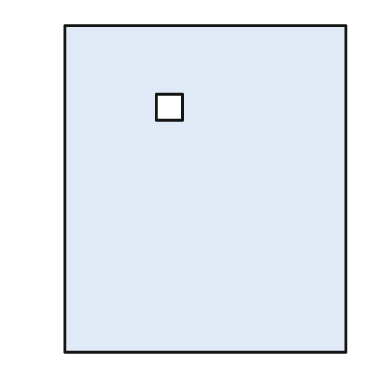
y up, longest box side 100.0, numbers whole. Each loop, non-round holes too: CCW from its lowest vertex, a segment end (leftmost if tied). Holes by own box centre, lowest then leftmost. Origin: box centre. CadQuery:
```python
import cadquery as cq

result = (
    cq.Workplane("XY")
    .moveTo(-43.0, -50.0)
    .lineTo(43.0, -50.0)
    .lineTo(43.0, 50.0)
    .lineTo(-43.0, 50.0)
    .close()
    .moveTo(-15.0, 21.0)
    .lineTo(-7.0, 21.0)
    .lineTo(-7.0, 29.0)
    .lineTo(-15.0, 29.0)
    .close()
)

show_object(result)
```